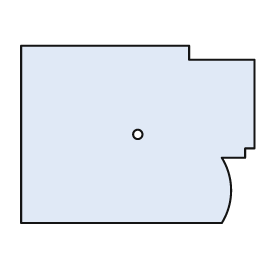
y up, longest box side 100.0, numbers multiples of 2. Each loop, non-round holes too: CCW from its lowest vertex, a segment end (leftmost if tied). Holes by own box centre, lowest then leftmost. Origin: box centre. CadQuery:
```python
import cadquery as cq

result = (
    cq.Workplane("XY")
    .moveTo(-50.0, -38.0)
    .lineTo(36.0, -38.0)
    .threePointArc((40.0, -24.0), (36.0, -10.0))
    .lineTo(46.0, -10.0)
    .lineTo(46.0, -6.0)
    .lineTo(50.0, -6.0)
    .lineTo(50.0, 32.0)
    .lineTo(22.0, 32.0)
    .lineTo(22.0, 38.0)
    .lineTo(-50.0, 38.0)
    .close()
    .moveTo(0.0, 0.0)
    .circle(2.0)
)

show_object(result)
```